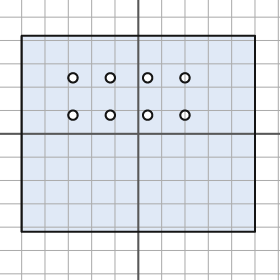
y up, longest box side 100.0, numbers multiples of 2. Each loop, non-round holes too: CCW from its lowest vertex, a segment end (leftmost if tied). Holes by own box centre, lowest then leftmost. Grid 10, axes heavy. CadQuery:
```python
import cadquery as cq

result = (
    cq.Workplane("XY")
    .moveTo(-50.0, -42.0)
    .lineTo(50.0, -42.0)
    .lineTo(50.0, 42.0)
    .lineTo(-50.0, 42.0)
    .close()
    .moveTo(-28.0, 8.0)
    .circle(2.0)
    .moveTo(-12.0, 8.0)
    .circle(2.0)
    .moveTo(4.0, 8.0)
    .circle(2.0)
    .moveTo(20.0, 8.0)
    .circle(2.0)
    .moveTo(-28.0, 24.0)
    .circle(2.0)
    .moveTo(-12.0, 24.0)
    .circle(2.0)
    .moveTo(4.0, 24.0)
    .circle(2.0)
    .moveTo(20.0, 24.0)
    .circle(2.0)
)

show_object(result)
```